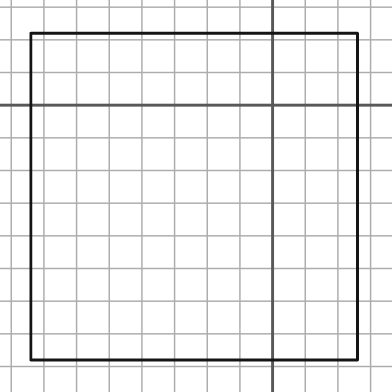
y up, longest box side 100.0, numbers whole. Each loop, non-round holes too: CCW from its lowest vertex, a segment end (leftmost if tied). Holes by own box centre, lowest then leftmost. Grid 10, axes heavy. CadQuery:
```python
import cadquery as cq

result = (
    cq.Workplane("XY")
    .moveTo(-74.0, -78.0)
    .lineTo(26.0, -78.0)
    .lineTo(26.0, 22.0)
    .lineTo(-74.0, 22.0)
    .close()
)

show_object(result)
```